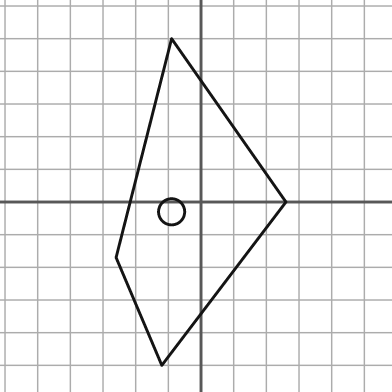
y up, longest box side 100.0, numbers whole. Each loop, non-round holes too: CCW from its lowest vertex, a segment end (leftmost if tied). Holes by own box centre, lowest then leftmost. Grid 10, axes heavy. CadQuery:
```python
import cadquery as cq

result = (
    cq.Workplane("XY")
    .moveTo(-12.0, -50.0)
    .lineTo(26.0, 0.0)
    .lineTo(-9.0, 50.0)
    .lineTo(-26.0, -17.0)
    .close()
    .moveTo(-9.0, -3.0)
    .circle(4.0)
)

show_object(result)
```